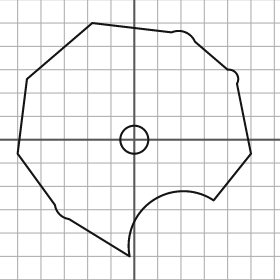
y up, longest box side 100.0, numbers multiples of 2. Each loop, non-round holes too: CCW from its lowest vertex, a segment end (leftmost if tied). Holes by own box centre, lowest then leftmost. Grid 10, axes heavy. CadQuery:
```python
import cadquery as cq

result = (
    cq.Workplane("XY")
    .moveTo(-2.0, -50.0)
    .threePointArc((8.0, -26.0), (34.0, -26.0))
    .lineTo(50.0, -6.0)
    .lineTo(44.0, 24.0)
    .threePointArc((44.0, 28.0), (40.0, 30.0))
    .lineTo(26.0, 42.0)
    .threePointArc((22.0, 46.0), (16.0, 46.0))
    .lineTo(-18.0, 50.0)
    .lineTo(-46.0, 26.0)
    .lineTo(-50.0, -6.0)
    .lineTo(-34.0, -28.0)
    .threePointArc((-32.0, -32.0), (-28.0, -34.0))
    .close()
    .moveTo(0.0, 0.0)
    .circle(6.0)
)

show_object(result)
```